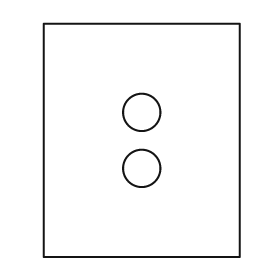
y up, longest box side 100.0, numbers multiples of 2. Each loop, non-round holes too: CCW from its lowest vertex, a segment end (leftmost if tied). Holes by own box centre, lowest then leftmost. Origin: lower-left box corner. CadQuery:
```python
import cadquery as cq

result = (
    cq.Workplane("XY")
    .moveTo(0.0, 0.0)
    .lineTo(84.0, 0.0)
    .lineTo(84.0, 100.0)
    .lineTo(0.0, 100.0)
    .close()
    .moveTo(42.0, 38.0)
    .circle(8.0)
    .moveTo(42.0, 62.0)
    .circle(8.0)
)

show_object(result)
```